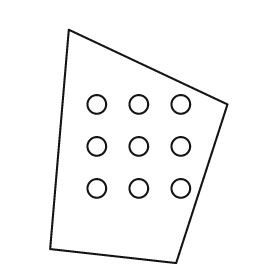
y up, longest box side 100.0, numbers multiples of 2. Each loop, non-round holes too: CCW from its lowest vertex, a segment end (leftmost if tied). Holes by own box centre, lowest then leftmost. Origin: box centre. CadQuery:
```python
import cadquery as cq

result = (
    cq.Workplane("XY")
    .moveTo(16.0, -50.0)
    .lineTo(38.0, 18.0)
    .lineTo(-30.0, 50.0)
    .lineTo(-38.0, -44.0)
    .close()
    .moveTo(-18.0, -18.0)
    .circle(4.0)
    .moveTo(0.0, -18.0)
    .circle(4.0)
    .moveTo(18.0, -18.0)
    .circle(4.0)
    .moveTo(-18.0, 0.0)
    .circle(4.0)
    .moveTo(0.0, 0.0)
    .circle(4.0)
    .moveTo(18.0, 0.0)
    .circle(4.0)
    .moveTo(-18.0, 18.0)
    .circle(4.0)
    .moveTo(0.0, 18.0)
    .circle(4.0)
    .moveTo(18.0, 18.0)
    .circle(4.0)
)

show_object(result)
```